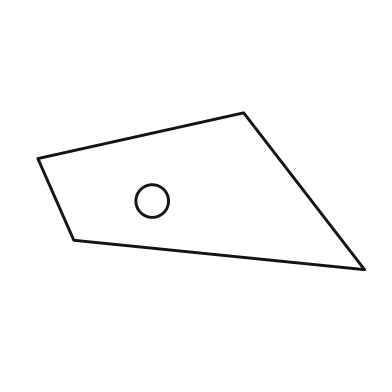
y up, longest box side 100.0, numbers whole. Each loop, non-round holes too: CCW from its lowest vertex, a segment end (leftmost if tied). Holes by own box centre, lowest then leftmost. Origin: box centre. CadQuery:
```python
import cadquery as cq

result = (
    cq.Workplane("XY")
    .moveTo(50.0, -24.0)
    .lineTo(13.0, 24.0)
    .lineTo(-50.0, 10.0)
    .lineTo(-39.0, -15.0)
    .close()
    .moveTo(-15.0, -3.0)
    .circle(5.0)
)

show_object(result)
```